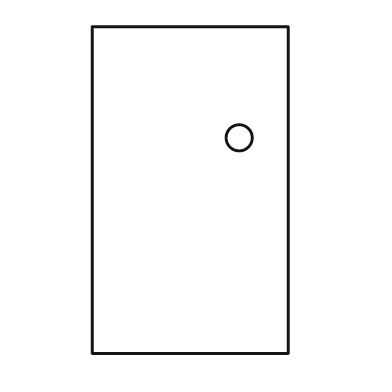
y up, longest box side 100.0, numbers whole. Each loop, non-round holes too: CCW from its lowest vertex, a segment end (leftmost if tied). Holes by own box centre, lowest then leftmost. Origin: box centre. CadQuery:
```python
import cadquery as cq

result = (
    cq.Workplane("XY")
    .moveTo(-30.0, -50.0)
    .lineTo(30.0, -50.0)
    .lineTo(30.0, 50.0)
    .lineTo(-30.0, 50.0)
    .close()
    .moveTo(15.0, 16.0)
    .circle(4.0)
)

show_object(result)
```